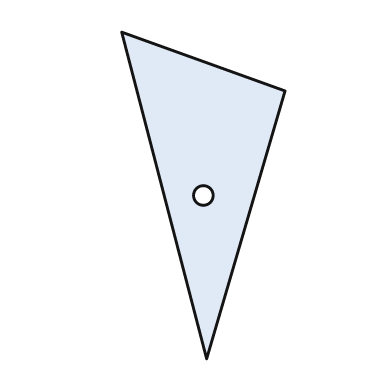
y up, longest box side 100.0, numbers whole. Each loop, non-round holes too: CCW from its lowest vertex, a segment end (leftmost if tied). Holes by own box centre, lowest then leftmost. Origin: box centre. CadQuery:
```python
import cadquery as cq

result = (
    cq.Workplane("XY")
    .moveTo(1.0, -50.0)
    .lineTo(25.0, 32.0)
    .lineTo(-25.0, 50.0)
    .close()
    .moveTo(0.0, 0.0)
    .circle(3.0)
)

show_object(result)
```